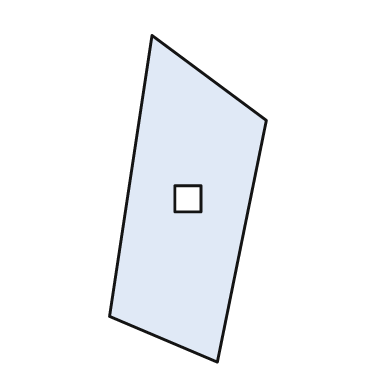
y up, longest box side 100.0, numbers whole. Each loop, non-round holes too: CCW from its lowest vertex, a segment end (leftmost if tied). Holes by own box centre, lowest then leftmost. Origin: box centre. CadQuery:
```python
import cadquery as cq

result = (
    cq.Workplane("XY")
    .moveTo(9.0, -50.0)
    .lineTo(24.0, 24.0)
    .lineTo(-11.0, 50.0)
    .lineTo(-24.0, -36.0)
    .close()
    .moveTo(-4.0, -4.0)
    .lineTo(4.0, -4.0)
    .lineTo(4.0, 4.0)
    .lineTo(-4.0, 4.0)
    .close()
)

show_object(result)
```